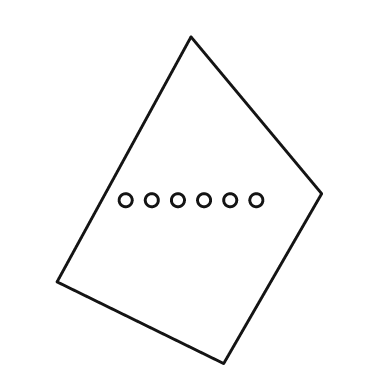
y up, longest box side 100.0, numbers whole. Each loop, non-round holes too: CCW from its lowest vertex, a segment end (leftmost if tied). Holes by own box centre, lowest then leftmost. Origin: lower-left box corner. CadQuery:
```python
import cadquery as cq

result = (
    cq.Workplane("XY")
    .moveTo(51.0, 0.0)
    .lineTo(81.0, 52.0)
    .lineTo(41.0, 100.0)
    .lineTo(0.0, 25.0)
    .close()
    .moveTo(21.0, 50.0)
    .circle(2.0)
    .moveTo(29.0, 50.0)
    .circle(2.0)
    .moveTo(37.0, 50.0)
    .circle(2.0)
    .moveTo(45.0, 50.0)
    .circle(2.0)
    .moveTo(53.0, 50.0)
    .circle(2.0)
    .moveTo(61.0, 50.0)
    .circle(2.0)
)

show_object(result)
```